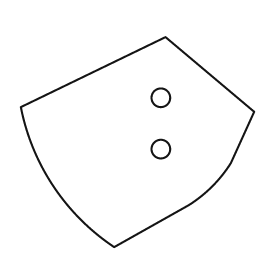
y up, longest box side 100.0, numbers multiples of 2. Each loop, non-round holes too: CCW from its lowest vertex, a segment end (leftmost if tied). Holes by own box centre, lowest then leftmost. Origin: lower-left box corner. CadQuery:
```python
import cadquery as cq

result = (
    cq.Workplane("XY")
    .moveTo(40.0, 0.0)
    .lineTo(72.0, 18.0)
    .threePointArc((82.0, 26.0), (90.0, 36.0))
    .lineTo(100.0, 58.0)
    .lineTo(62.0, 90.0)
    .lineTo(0.0, 60.0)
    .threePointArc((14.0, 26.0), (40.0, 0.0))
    .close()
    .moveTo(60.0, 42.0)
    .circle(4.0)
    .moveTo(60.0, 64.0)
    .circle(4.0)
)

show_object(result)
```